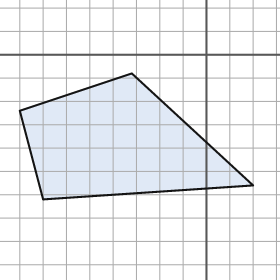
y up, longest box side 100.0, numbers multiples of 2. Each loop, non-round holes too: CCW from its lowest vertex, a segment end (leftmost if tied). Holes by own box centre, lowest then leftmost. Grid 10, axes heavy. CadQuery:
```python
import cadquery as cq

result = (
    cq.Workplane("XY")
    .moveTo(-70.0, -62.0)
    .lineTo(20.0, -56.0)
    .lineTo(-32.0, -8.0)
    .lineTo(-80.0, -24.0)
    .close()
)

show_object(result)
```